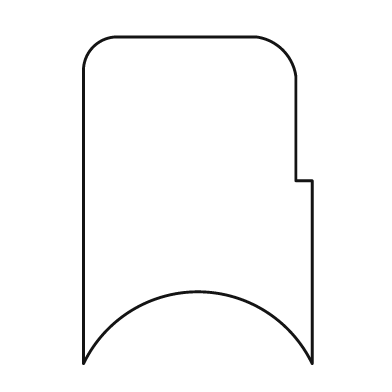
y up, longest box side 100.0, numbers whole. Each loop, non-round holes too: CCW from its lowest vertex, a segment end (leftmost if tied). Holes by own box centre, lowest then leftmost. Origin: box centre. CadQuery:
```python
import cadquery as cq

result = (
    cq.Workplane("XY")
    .moveTo(-35.0, -50.0)
    .threePointArc((0.0, -28.0), (35.0, -50.0))
    .lineTo(35.0, 6.0)
    .lineTo(30.0, 6.0)
    .lineTo(30.0, 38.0)
    .threePointArc((26.0, 46.0), (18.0, 50.0))
    .lineTo(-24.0, 50.0)
    .threePointArc((-32.0, 47.0), (-35.0, 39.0))
    .close()
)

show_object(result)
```